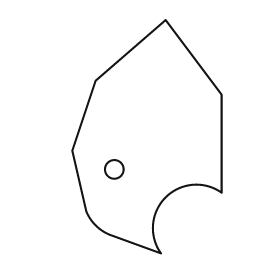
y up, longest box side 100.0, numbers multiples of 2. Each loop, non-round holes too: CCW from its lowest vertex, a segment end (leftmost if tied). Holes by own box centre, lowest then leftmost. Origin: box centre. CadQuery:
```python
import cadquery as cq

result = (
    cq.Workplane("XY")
    .moveTo(6.0, -50.0)
    .threePointArc((8.0, -26.0), (32.0, -24.0))
    .lineTo(32.0, 18.0)
    .lineTo(8.0, 50.0)
    .lineTo(-22.0, 24.0)
    .lineTo(-32.0, -6.0)
    .lineTo(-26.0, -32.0)
    .threePointArc((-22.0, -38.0), (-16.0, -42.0))
    .close()
    .moveTo(-14.0, -14.0)
    .circle(4.0)
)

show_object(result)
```